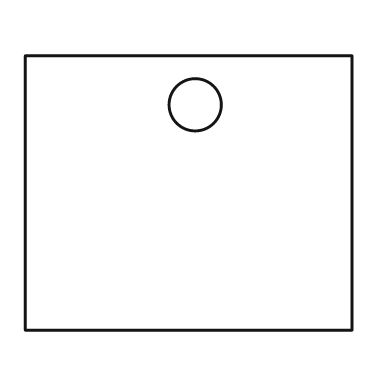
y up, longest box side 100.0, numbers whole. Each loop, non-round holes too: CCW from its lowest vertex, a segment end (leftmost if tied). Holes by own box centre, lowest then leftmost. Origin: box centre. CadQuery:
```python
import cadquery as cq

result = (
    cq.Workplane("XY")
    .moveTo(-50.0, -42.0)
    .lineTo(50.0, -42.0)
    .lineTo(50.0, 42.0)
    .lineTo(-50.0, 42.0)
    .close()
    .moveTo(2.0, 27.0)
    .circle(8.0)
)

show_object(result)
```